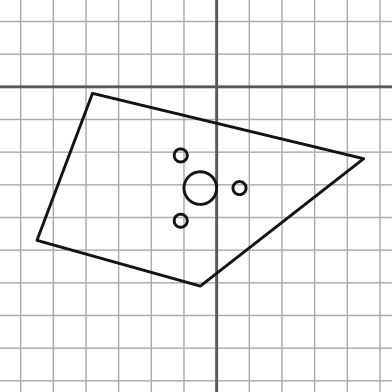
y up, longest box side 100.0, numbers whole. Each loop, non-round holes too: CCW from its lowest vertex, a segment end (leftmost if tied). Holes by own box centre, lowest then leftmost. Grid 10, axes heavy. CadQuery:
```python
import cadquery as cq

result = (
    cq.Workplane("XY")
    .moveTo(-5.0, -61.0)
    .lineTo(45.0, -22.0)
    .lineTo(-38.0, -2.0)
    .lineTo(-55.0, -47.0)
    .close()
    .moveTo(-11.0, -41.0)
    .circle(2.0)
    .moveTo(-5.0, -31.0)
    .circle(5.0)
    .moveTo(7.0, -31.0)
    .circle(2.0)
    .moveTo(-11.0, -21.0)
    .circle(2.0)
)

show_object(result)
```